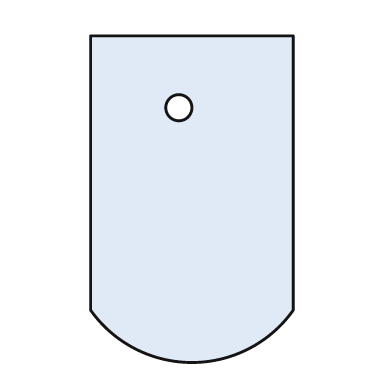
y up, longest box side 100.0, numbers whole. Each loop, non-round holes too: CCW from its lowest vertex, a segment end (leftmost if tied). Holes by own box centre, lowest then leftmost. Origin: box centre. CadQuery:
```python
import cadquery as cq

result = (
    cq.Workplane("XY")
    .moveTo(-31.0, -34.0)
    .threePointArc((0.0, -50.0), (31.0, -34.0))
    .lineTo(31.0, 50.0)
    .lineTo(-31.0, 50.0)
    .close()
    .moveTo(-4.0, 28.0)
    .circle(4.0)
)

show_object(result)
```